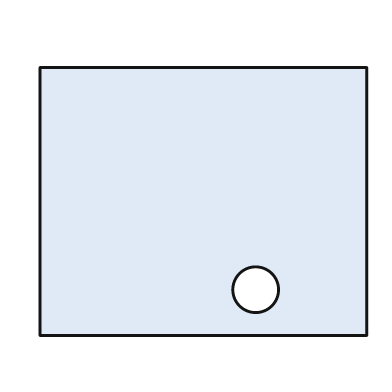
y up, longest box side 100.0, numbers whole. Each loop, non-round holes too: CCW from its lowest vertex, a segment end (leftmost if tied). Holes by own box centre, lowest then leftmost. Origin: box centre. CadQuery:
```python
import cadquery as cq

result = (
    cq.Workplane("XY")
    .moveTo(-50.0, -41.0)
    .lineTo(50.0, -41.0)
    .lineTo(50.0, 41.0)
    .lineTo(-50.0, 41.0)
    .close()
    .moveTo(16.0, -27.0)
    .circle(7.0)
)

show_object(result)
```